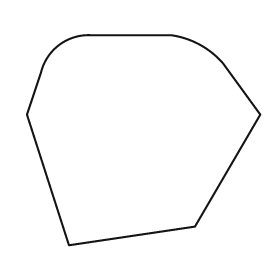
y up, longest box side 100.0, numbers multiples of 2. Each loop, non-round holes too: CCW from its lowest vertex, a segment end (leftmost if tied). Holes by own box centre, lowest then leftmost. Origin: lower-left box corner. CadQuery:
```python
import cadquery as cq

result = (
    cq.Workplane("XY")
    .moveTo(18.0, 0.0)
    .lineTo(72.0, 8.0)
    .lineTo(100.0, 56.0)
    .lineTo(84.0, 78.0)
    .threePointArc((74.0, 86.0), (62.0, 90.0))
    .lineTo(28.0, 90.0)
    .threePointArc((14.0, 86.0), (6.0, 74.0))
    .lineTo(0.0, 56.0)
    .close()
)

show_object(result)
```